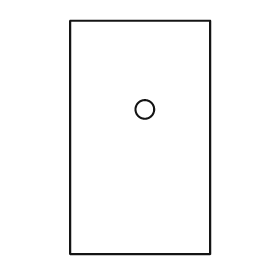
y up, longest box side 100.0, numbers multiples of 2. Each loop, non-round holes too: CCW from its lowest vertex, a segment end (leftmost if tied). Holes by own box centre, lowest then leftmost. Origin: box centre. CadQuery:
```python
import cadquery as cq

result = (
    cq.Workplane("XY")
    .moveTo(-30.0, -50.0)
    .lineTo(30.0, -50.0)
    .lineTo(30.0, 50.0)
    .lineTo(-30.0, 50.0)
    .close()
    .moveTo(2.0, 12.0)
    .circle(4.0)
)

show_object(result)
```